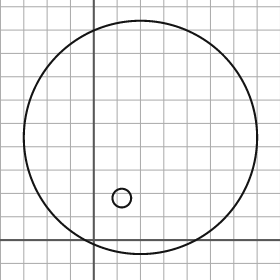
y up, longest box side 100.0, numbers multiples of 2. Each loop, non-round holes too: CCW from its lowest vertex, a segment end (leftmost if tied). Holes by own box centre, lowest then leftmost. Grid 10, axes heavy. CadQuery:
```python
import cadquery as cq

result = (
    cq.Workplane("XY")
    .moveTo(20.0, 44.0)
    .circle(50.0)
    .moveTo(12.0, 18.0)
    .circle(4.0)
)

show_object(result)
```